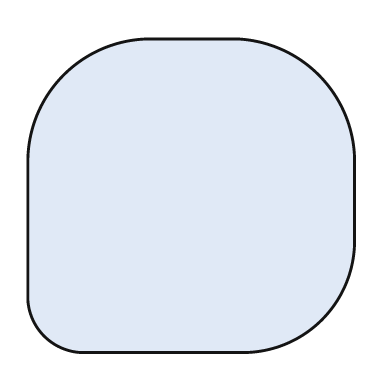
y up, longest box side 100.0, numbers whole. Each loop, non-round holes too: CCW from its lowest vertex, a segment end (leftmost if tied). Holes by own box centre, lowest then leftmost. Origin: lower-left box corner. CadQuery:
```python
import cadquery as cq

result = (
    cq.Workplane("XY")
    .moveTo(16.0, 0.0)
    .lineTo(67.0, 0.0)
    .threePointArc((90.0, 10.0), (100.0, 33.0))
    .lineTo(100.0, 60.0)
    .threePointArc((89.0, 85.0), (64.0, 96.0))
    .lineTo(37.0, 96.0)
    .threePointArc((11.0, 85.0), (0.0, 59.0))
    .lineTo(0.0, 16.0)
    .threePointArc((5.0, 5.0), (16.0, 0.0))
    .close()
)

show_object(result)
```